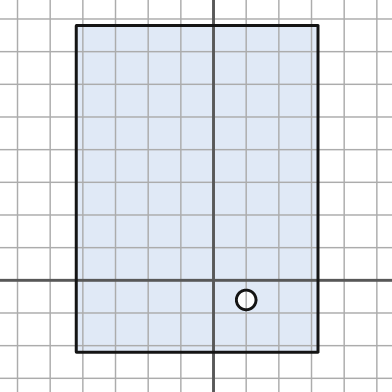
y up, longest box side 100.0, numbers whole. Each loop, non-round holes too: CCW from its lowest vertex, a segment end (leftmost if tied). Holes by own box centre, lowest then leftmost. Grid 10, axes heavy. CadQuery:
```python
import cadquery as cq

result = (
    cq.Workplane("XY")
    .moveTo(-42.0, -22.0)
    .lineTo(32.0, -22.0)
    .lineTo(32.0, 78.0)
    .lineTo(-42.0, 78.0)
    .close()
    .moveTo(10.0, -6.0)
    .circle(3.0)
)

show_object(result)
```